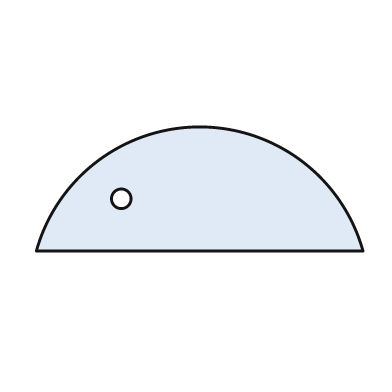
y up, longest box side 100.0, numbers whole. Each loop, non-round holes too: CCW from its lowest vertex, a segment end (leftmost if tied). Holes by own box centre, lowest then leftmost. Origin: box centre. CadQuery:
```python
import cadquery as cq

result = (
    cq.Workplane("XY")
    .moveTo(-50.0, -19.0)
    .lineTo(50.0, -19.0)
    .threePointArc((0.0, 19.0), (-50.0, -19.0))
    .close()
    .moveTo(-24.0, -3.0)
    .circle(3.0)
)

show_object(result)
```